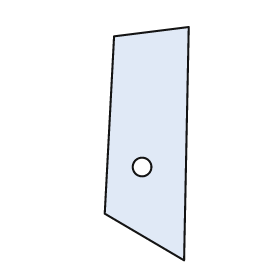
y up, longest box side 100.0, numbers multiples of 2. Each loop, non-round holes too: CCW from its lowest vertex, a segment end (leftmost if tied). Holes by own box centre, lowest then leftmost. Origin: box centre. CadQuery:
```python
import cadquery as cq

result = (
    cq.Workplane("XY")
    .moveTo(16.0, -50.0)
    .lineTo(18.0, 50.0)
    .lineTo(-14.0, 46.0)
    .lineTo(-18.0, -30.0)
    .close()
    .moveTo(-2.0, -10.0)
    .circle(4.0)
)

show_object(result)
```